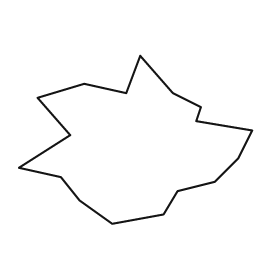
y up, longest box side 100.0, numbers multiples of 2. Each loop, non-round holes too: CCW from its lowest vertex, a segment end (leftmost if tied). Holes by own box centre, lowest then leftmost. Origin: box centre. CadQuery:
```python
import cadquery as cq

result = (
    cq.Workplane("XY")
    .moveTo(-10.0, -36.0)
    .lineTo(12.0, -32.0)
    .lineTo(18.0, -22.0)
    .lineTo(34.0, -18.0)
    .lineTo(44.0, -8.0)
    .lineTo(50.0, 4.0)
    .lineTo(26.0, 8.0)
    .lineTo(28.0, 14.0)
    .lineTo(16.0, 20.0)
    .lineTo(2.0, 36.0)
    .lineTo(-4.0, 20.0)
    .lineTo(-22.0, 24.0)
    .lineTo(-42.0, 18.0)
    .lineTo(-28.0, 2.0)
    .lineTo(-50.0, -12.0)
    .lineTo(-32.0, -16.0)
    .lineTo(-24.0, -26.0)
    .close()
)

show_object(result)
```